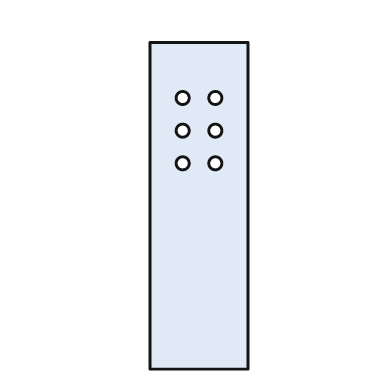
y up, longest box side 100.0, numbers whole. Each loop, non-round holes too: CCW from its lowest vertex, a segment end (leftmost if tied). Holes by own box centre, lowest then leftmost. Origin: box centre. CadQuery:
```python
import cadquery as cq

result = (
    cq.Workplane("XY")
    .moveTo(-15.0, -50.0)
    .lineTo(15.0, -50.0)
    .lineTo(15.0, 50.0)
    .lineTo(-15.0, 50.0)
    .close()
    .moveTo(-5.0, 13.0)
    .circle(2.0)
    .moveTo(5.0, 13.0)
    .circle(2.0)
    .moveTo(-5.0, 23.0)
    .circle(2.0)
    .moveTo(5.0, 23.0)
    .circle(2.0)
    .moveTo(-5.0, 33.0)
    .circle(2.0)
    .moveTo(5.0, 33.0)
    .circle(2.0)
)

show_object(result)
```